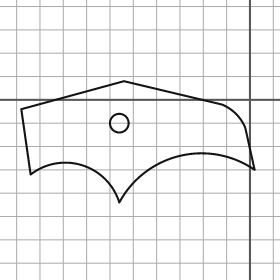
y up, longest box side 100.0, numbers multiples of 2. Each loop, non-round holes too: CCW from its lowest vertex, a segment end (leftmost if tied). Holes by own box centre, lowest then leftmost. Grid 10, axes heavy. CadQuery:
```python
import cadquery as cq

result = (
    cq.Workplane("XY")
    .moveTo(-56.0, -44.0)
    .threePointArc((-30.0, -24.0), (2.0, -30.0))
    .lineTo(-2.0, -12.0)
    .threePointArc((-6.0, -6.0), (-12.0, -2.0))
    .lineTo(-54.0, 8.0)
    .lineTo(-98.0, -4.0)
    .lineTo(-94.0, -32.0)
    .threePointArc((-72.0, -28.0), (-56.0, -44.0))
    .close()
    .moveTo(-56.0, -10.0)
    .circle(4.0)
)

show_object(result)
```